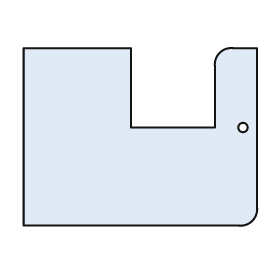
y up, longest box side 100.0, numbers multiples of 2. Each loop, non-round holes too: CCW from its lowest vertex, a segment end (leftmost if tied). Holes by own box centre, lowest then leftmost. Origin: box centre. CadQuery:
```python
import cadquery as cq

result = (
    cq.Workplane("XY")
    .moveTo(-50.0, -38.0)
    .lineTo(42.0, -38.0)
    .threePointArc((48.0, -36.0), (50.0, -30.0))
    .lineTo(50.0, 38.0)
    .lineTo(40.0, 38.0)
    .threePointArc((34.0, 36.0), (32.0, 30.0))
    .lineTo(32.0, 4.0)
    .lineTo(-4.0, 4.0)
    .lineTo(-4.0, 38.0)
    .lineTo(-50.0, 38.0)
    .close()
    .moveTo(44.0, 4.0)
    .circle(2.0)
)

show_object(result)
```